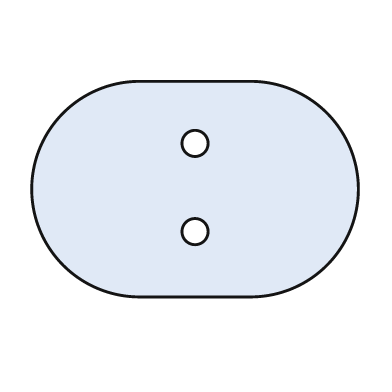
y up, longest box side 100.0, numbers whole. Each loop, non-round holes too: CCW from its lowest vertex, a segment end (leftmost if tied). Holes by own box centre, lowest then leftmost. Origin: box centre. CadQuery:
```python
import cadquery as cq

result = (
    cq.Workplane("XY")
    .moveTo(-17.0, -33.0)
    .lineTo(17.0, -33.0)
    .threePointArc((50.0, 0.0), (17.0, 33.0))
    .lineTo(-17.0, 33.0)
    .threePointArc((-50.0, 0.0), (-17.0, -33.0))
    .close()
    .moveTo(0.0, -13.0)
    .circle(4.0)
    .moveTo(0.0, 14.0)
    .circle(4.0)
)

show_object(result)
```